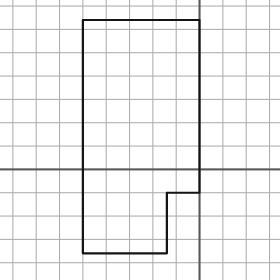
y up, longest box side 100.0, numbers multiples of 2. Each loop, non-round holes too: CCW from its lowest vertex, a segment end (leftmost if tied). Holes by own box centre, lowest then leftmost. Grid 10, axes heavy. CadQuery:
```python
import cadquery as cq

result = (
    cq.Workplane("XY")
    .moveTo(-50.0, -36.0)
    .lineTo(-14.0, -36.0)
    .lineTo(-14.0, -10.0)
    .lineTo(0.0, -10.0)
    .lineTo(0.0, 64.0)
    .lineTo(-50.0, 64.0)
    .close()
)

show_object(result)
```